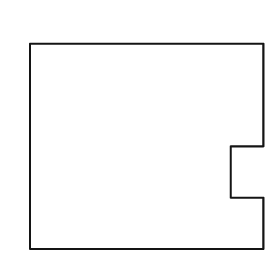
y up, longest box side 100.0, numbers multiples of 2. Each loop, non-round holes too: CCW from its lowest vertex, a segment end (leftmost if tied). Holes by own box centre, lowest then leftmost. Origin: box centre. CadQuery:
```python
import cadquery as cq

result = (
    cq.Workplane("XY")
    .moveTo(-50.0, -44.0)
    .lineTo(50.0, -44.0)
    .lineTo(50.0, -22.0)
    .lineTo(36.0, -22.0)
    .lineTo(36.0, 0.0)
    .lineTo(50.0, 0.0)
    .lineTo(50.0, 44.0)
    .lineTo(-50.0, 44.0)
    .close()
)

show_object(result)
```